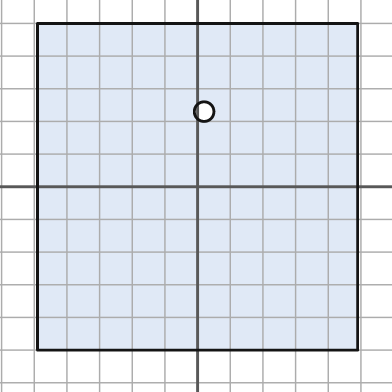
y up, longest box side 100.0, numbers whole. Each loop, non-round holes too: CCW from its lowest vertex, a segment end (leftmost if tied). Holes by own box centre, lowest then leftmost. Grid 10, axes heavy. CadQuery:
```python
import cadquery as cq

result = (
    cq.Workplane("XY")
    .moveTo(-49.0, -50.0)
    .lineTo(49.0, -50.0)
    .lineTo(49.0, 50.0)
    .lineTo(-49.0, 50.0)
    .close()
    .moveTo(2.0, 23.0)
    .circle(3.0)
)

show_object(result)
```